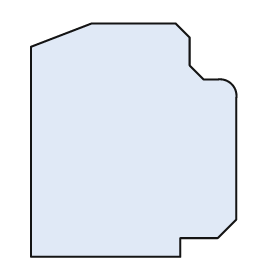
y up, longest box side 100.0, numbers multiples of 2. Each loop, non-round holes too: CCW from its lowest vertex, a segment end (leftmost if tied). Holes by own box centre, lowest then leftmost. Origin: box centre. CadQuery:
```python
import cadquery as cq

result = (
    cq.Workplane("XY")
    .moveTo(-44.0, -50.0)
    .lineTo(20.0, -50.0)
    .lineTo(20.0, -42.0)
    .lineTo(36.0, -42.0)
    .lineTo(44.0, -34.0)
    .lineTo(44.0, 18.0)
    .threePointArc((42.0, 24.0), (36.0, 26.0))
    .lineTo(30.0, 26.0)
    .lineTo(24.0, 32.0)
    .lineTo(24.0, 44.0)
    .lineTo(18.0, 50.0)
    .lineTo(-18.0, 50.0)
    .lineTo(-44.0, 40.0)
    .close()
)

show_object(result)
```